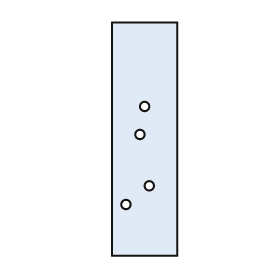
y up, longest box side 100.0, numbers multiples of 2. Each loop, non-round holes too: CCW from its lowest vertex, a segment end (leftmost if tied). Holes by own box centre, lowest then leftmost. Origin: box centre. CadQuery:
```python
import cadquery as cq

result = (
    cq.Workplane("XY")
    .moveTo(-14.0, -50.0)
    .lineTo(14.0, -50.0)
    .lineTo(14.0, 50.0)
    .lineTo(-14.0, 50.0)
    .close()
    .moveTo(-8.0, -28.0)
    .circle(2.0)
    .moveTo(2.0, -20.0)
    .circle(2.0)
    .moveTo(-2.0, 2.0)
    .circle(2.0)
    .moveTo(0.0, 14.0)
    .circle(2.0)
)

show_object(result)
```